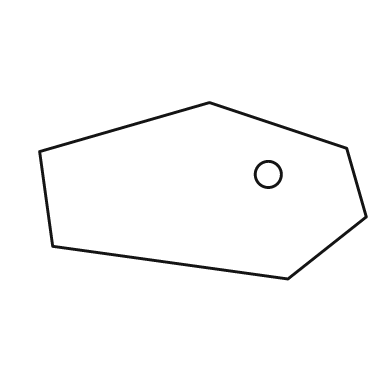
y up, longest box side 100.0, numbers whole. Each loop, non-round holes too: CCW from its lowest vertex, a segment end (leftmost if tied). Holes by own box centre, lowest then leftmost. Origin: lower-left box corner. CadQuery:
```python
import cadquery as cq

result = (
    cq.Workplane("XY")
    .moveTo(76.0, 0.0)
    .lineTo(100.0, 19.0)
    .lineTo(94.0, 40.0)
    .lineTo(52.0, 54.0)
    .lineTo(0.0, 39.0)
    .lineTo(4.0, 10.0)
    .close()
    .moveTo(70.0, 32.0)
    .circle(4.0)
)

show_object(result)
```